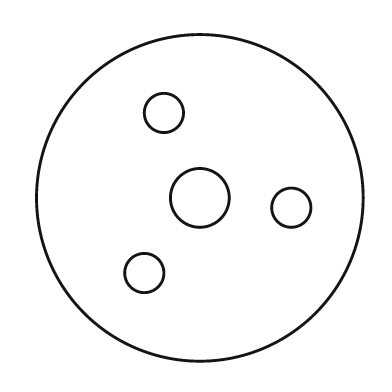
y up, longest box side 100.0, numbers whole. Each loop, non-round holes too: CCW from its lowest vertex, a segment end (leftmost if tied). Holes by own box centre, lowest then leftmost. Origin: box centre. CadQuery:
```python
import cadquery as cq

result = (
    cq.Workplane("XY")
    .moveTo(0.0, 0.0)
    .circle(50.0)
    .moveTo(-17.0, -23.0)
    .circle(6.0)
    .moveTo(28.0, -3.0)
    .circle(6.0)
    .moveTo(0.0, 0.0)
    .circle(9.0)
    .moveTo(-11.0, 26.0)
    .circle(6.0)
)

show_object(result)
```